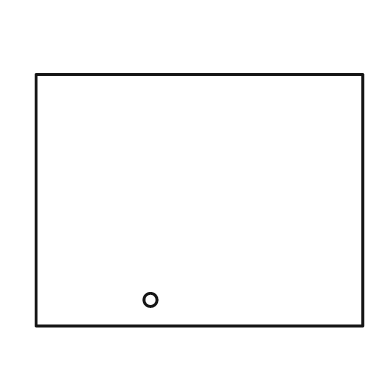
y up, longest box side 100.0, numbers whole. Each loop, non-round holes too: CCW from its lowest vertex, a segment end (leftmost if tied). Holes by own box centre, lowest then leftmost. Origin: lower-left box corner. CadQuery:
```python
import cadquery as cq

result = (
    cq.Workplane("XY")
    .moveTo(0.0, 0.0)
    .lineTo(100.0, 0.0)
    .lineTo(100.0, 77.0)
    .lineTo(0.0, 77.0)
    .close()
    .moveTo(35.0, 8.0)
    .circle(2.0)
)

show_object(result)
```